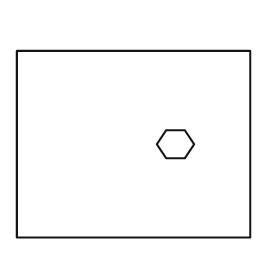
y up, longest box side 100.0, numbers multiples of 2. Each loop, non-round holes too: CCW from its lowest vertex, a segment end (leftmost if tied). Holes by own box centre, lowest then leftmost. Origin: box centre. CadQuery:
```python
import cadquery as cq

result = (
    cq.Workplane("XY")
    .moveTo(-50.0, -40.0)
    .lineTo(50.0, -40.0)
    .lineTo(50.0, 40.0)
    .lineTo(-50.0, 40.0)
    .close()
    .moveTo(14.0, -6.0)
    .lineTo(22.0, -6.0)
    .lineTo(26.0, 0.0)
    .lineTo(22.0, 6.0)
    .lineTo(14.0, 6.0)
    .lineTo(10.0, 0.0)
    .close()
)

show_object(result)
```